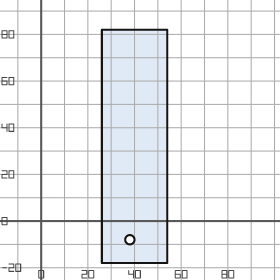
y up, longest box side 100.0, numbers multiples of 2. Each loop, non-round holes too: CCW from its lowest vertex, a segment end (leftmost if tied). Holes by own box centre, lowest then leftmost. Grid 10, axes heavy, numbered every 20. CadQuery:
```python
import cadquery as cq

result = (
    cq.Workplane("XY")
    .moveTo(26.0, -18.0)
    .lineTo(54.0, -18.0)
    .lineTo(54.0, 82.0)
    .lineTo(26.0, 82.0)
    .close()
    .moveTo(38.0, -8.0)
    .circle(2.0)
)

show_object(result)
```